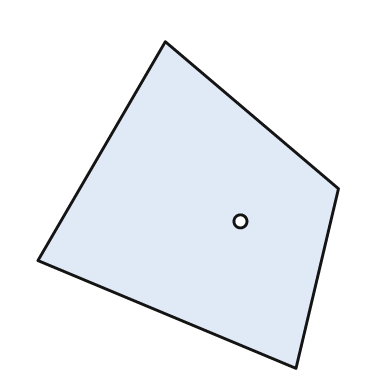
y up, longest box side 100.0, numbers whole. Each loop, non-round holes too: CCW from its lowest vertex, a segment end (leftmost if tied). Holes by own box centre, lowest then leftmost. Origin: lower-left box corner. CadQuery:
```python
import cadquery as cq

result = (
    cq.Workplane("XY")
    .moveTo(79.0, 0.0)
    .lineTo(92.0, 55.0)
    .lineTo(39.0, 100.0)
    .lineTo(0.0, 33.0)
    .close()
    .moveTo(62.0, 45.0)
    .circle(2.0)
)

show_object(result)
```